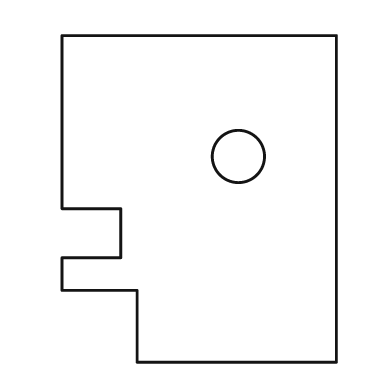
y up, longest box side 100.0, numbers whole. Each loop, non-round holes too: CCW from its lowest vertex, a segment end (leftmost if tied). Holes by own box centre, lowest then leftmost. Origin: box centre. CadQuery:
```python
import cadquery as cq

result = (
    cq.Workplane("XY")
    .moveTo(-19.0, -50.0)
    .lineTo(42.0, -50.0)
    .lineTo(42.0, 50.0)
    .lineTo(-42.0, 50.0)
    .lineTo(-42.0, -3.0)
    .lineTo(-24.0, -3.0)
    .lineTo(-24.0, -18.0)
    .lineTo(-42.0, -18.0)
    .lineTo(-42.0, -28.0)
    .lineTo(-19.0, -28.0)
    .close()
    .moveTo(12.0, 13.0)
    .circle(8.0)
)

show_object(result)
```